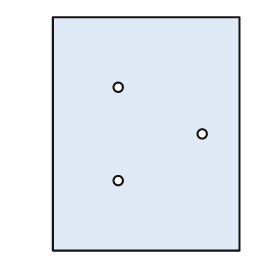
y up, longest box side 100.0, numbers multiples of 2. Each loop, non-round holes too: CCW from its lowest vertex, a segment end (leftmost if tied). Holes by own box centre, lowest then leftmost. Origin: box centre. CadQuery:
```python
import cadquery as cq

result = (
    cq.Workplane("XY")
    .moveTo(-40.0, -50.0)
    .lineTo(40.0, -50.0)
    .lineTo(40.0, 50.0)
    .lineTo(-40.0, 50.0)
    .close()
    .moveTo(-12.0, -20.0)
    .circle(2.0)
    .moveTo(24.0, 0.0)
    .circle(2.0)
    .moveTo(-12.0, 20.0)
    .circle(2.0)
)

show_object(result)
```